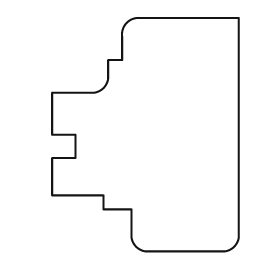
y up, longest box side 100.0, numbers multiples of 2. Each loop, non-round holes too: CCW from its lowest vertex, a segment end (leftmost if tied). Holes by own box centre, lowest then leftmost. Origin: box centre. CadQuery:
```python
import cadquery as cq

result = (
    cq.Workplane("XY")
    .moveTo(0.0, -50.0)
    .lineTo(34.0, -50.0)
    .threePointArc((38.0, -48.0), (40.0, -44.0))
    .lineTo(40.0, 50.0)
    .lineTo(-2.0, 50.0)
    .threePointArc((-8.0, 48.0), (-10.0, 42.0))
    .lineTo(-10.0, 32.0)
    .lineTo(-16.0, 32.0)
    .lineTo(-16.0, 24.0)
    .threePointArc((-18.0, 20.0), (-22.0, 18.0))
    .lineTo(-40.0, 18.0)
    .lineTo(-40.0, 0.0)
    .lineTo(-30.0, 0.0)
    .lineTo(-30.0, -10.0)
    .lineTo(-40.0, -10.0)
    .lineTo(-40.0, -26.0)
    .lineTo(-18.0, -26.0)
    .lineTo(-18.0, -32.0)
    .lineTo(-6.0, -32.0)
    .lineTo(-6.0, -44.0)
    .threePointArc((-4.0, -48.0), (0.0, -50.0))
    .close()
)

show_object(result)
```